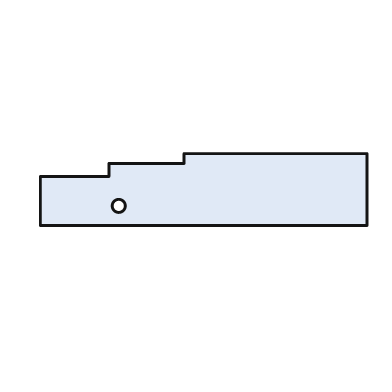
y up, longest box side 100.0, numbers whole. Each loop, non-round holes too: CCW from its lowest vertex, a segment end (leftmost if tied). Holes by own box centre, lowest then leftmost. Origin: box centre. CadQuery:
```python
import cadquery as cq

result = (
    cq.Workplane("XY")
    .moveTo(-50.0, -11.0)
    .lineTo(50.0, -11.0)
    .lineTo(50.0, 11.0)
    .lineTo(-6.0, 11.0)
    .lineTo(-6.0, 8.0)
    .lineTo(-29.0, 8.0)
    .lineTo(-29.0, 4.0)
    .lineTo(-50.0, 4.0)
    .close()
    .moveTo(-26.0, -5.0)
    .circle(2.0)
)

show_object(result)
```